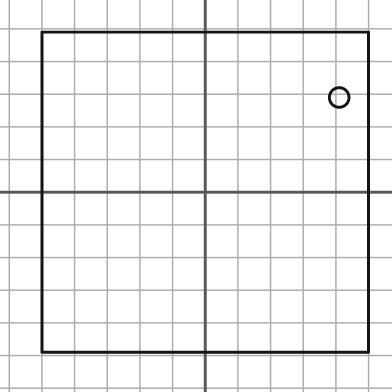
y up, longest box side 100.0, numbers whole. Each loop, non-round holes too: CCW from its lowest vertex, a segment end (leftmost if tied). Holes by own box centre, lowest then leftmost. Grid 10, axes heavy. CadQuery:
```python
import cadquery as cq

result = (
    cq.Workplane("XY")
    .moveTo(-50.0, -49.0)
    .lineTo(50.0, -49.0)
    .lineTo(50.0, 49.0)
    .lineTo(-50.0, 49.0)
    .close()
    .moveTo(41.0, 29.0)
    .circle(3.0)
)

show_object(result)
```